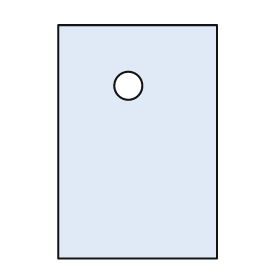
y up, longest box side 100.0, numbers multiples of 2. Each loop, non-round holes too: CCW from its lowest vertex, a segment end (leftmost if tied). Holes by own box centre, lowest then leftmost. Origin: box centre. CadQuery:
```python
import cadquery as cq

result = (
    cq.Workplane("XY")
    .moveTo(-34.0, -50.0)
    .lineTo(34.0, -50.0)
    .lineTo(34.0, 50.0)
    .lineTo(-34.0, 50.0)
    .close()
    .moveTo(-4.0, 24.0)
    .circle(6.0)
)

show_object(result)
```